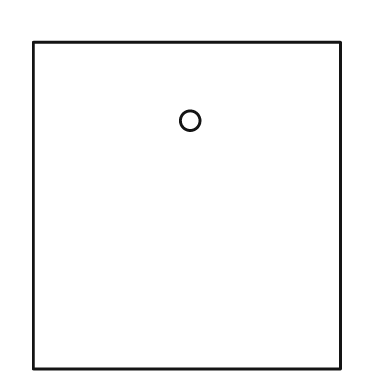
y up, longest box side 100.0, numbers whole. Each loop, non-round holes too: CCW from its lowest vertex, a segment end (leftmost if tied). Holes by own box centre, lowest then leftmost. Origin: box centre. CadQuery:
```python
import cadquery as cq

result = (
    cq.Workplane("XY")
    .moveTo(-47.0, -50.0)
    .lineTo(47.0, -50.0)
    .lineTo(47.0, 50.0)
    .lineTo(-47.0, 50.0)
    .close()
    .moveTo(1.0, 26.0)
    .circle(3.0)
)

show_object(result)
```